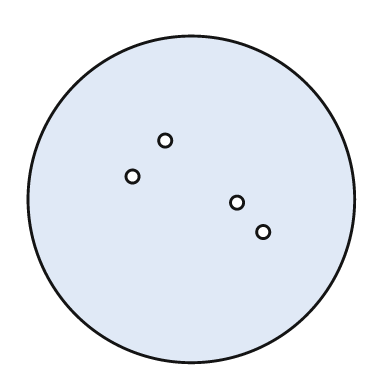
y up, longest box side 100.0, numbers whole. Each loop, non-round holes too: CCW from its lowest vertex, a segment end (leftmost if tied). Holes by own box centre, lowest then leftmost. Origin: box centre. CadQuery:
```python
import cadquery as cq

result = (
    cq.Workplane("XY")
    .moveTo(0.0, 0.0)
    .circle(50.0)
    .moveTo(22.0, -10.0)
    .circle(2.0)
    .moveTo(14.0, -1.0)
    .circle(2.0)
    .moveTo(-18.0, 7.0)
    .circle(2.0)
    .moveTo(-8.0, 18.0)
    .circle(2.0)
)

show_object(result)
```